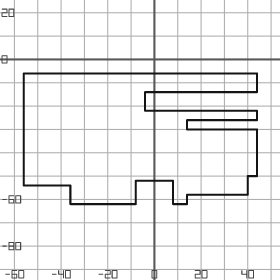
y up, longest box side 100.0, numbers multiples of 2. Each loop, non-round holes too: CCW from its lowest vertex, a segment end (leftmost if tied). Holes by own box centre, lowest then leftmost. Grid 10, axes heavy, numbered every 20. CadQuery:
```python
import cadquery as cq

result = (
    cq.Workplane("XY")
    .moveTo(-36.0, -62.0)
    .lineTo(-8.0, -62.0)
    .lineTo(-8.0, -52.0)
    .lineTo(8.0, -52.0)
    .lineTo(8.0, -62.0)
    .lineTo(14.0, -62.0)
    .lineTo(14.0, -58.0)
    .lineTo(40.0, -58.0)
    .lineTo(40.0, -50.0)
    .lineTo(44.0, -50.0)
    .lineTo(44.0, -30.0)
    .lineTo(14.0, -30.0)
    .lineTo(14.0, -26.0)
    .lineTo(44.0, -26.0)
    .lineTo(44.0, -22.0)
    .lineTo(-4.0, -22.0)
    .lineTo(-4.0, -14.0)
    .lineTo(44.0, -14.0)
    .lineTo(44.0, -6.0)
    .lineTo(-56.0, -6.0)
    .lineTo(-56.0, -54.0)
    .lineTo(-36.0, -54.0)
    .close()
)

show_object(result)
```